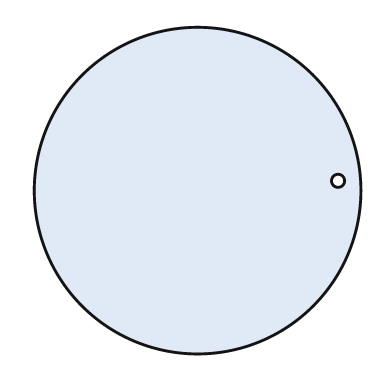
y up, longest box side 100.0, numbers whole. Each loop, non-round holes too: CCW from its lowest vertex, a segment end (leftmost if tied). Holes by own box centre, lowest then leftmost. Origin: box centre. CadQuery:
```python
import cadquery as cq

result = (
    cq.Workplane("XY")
    .moveTo(0.0, 0.0)
    .circle(50.0)
    .moveTo(43.0, 3.0)
    .circle(2.0)
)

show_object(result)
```